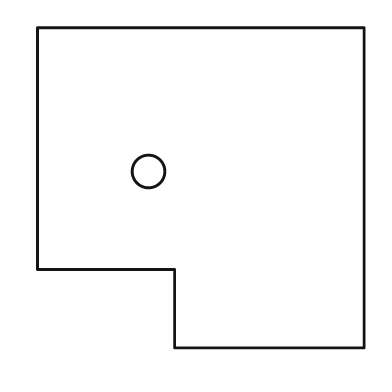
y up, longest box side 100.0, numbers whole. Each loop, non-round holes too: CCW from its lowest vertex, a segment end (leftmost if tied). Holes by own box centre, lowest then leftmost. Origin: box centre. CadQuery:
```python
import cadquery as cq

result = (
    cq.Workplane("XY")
    .moveTo(-8.0, -49.0)
    .lineTo(50.0, -49.0)
    .lineTo(50.0, 49.0)
    .lineTo(-50.0, 49.0)
    .lineTo(-50.0, -25.0)
    .lineTo(-8.0, -25.0)
    .close()
    .moveTo(-16.0, 5.0)
    .circle(5.0)
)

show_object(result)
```